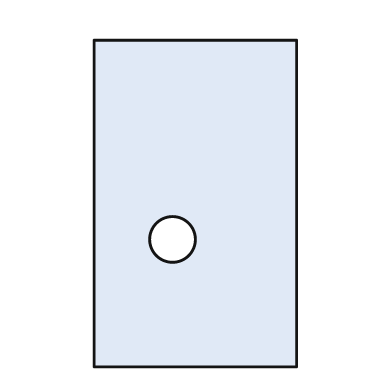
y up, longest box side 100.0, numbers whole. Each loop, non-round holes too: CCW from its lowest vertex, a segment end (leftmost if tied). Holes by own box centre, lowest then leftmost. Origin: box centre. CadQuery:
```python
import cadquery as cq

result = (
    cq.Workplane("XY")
    .moveTo(-31.0, -50.0)
    .lineTo(31.0, -50.0)
    .lineTo(31.0, 50.0)
    .lineTo(-31.0, 50.0)
    .close()
    .moveTo(-7.0, -11.0)
    .circle(7.0)
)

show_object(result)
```